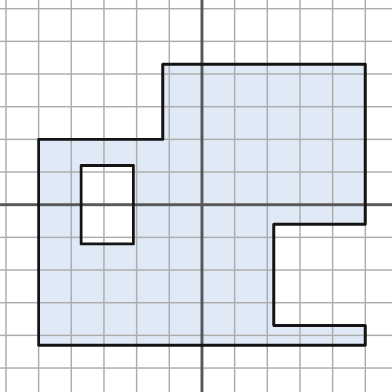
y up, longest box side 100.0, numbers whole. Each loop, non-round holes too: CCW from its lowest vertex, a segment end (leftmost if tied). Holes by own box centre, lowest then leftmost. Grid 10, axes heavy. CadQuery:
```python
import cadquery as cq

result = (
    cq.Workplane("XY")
    .moveTo(-50.0, -43.0)
    .lineTo(50.0, -43.0)
    .lineTo(50.0, -37.0)
    .lineTo(22.0, -37.0)
    .lineTo(22.0, -6.0)
    .lineTo(50.0, -6.0)
    .lineTo(50.0, 43.0)
    .lineTo(-12.0, 43.0)
    .lineTo(-12.0, 20.0)
    .lineTo(-50.0, 20.0)
    .close()
    .moveTo(-37.0, -12.0)
    .lineTo(-21.0, -12.0)
    .lineTo(-21.0, 12.0)
    .lineTo(-37.0, 12.0)
    .close()
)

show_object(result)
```